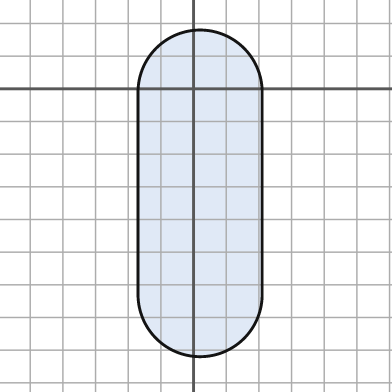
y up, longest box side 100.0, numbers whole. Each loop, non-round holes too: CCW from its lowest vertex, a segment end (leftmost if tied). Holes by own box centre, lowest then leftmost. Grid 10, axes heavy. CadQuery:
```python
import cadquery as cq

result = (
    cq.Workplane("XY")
    .moveTo(-17.0, -63.0)
    .threePointArc((2.0, -82.0), (21.0, -63.0))
    .lineTo(21.0, -1.0)
    .threePointArc((2.0, 18.0), (-17.0, -1.0))
    .close()
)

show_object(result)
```